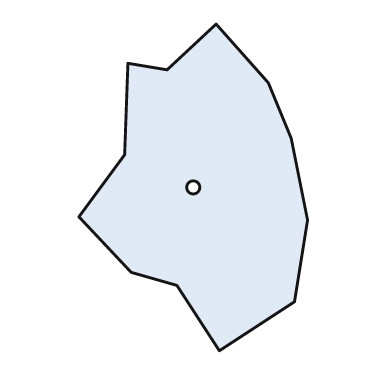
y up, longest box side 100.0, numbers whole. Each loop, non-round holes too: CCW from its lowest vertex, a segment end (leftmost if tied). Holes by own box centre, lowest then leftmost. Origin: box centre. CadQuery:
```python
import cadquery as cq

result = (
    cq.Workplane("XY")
    .moveTo(8.0, -50.0)
    .lineTo(31.0, -35.0)
    .lineTo(35.0, -10.0)
    .lineTo(30.0, 15.0)
    .lineTo(23.0, 32.0)
    .lineTo(7.0, 50.0)
    .lineTo(-8.0, 36.0)
    .lineTo(-20.0, 38.0)
    .lineTo(-21.0, 10.0)
    .lineTo(-35.0, -9.0)
    .lineTo(-19.0, -26.0)
    .lineTo(-5.0, -30.0)
    .close()
    .moveTo(0.0, 0.0)
    .circle(2.0)
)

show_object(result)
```